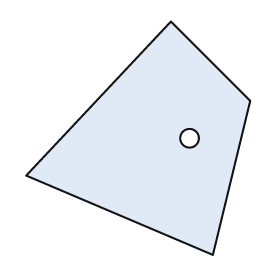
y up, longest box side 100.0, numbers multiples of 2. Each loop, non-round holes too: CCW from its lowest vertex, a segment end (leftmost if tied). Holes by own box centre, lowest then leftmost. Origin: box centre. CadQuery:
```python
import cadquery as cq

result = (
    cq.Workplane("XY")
    .moveTo(32.0, -50.0)
    .lineTo(48.0, 16.0)
    .lineTo(14.0, 50.0)
    .lineTo(-48.0, -16.0)
    .close()
    .moveTo(22.0, 0.0)
    .circle(4.0)
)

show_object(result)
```